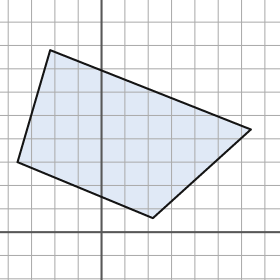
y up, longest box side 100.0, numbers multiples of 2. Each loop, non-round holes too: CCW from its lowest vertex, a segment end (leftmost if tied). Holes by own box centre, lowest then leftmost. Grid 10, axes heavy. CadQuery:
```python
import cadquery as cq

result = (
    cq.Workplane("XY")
    .moveTo(22.0, 6.0)
    .lineTo(64.0, 44.0)
    .lineTo(-22.0, 78.0)
    .lineTo(-36.0, 30.0)
    .close()
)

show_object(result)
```